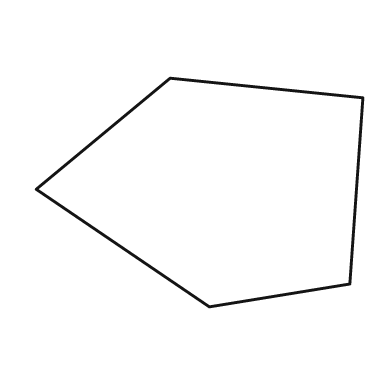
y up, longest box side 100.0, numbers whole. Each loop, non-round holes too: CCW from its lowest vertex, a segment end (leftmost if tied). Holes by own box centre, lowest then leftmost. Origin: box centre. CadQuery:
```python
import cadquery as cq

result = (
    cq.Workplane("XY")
    .moveTo(3.0, -35.0)
    .lineTo(46.0, -28.0)
    .lineTo(50.0, 29.0)
    .lineTo(-9.0, 35.0)
    .lineTo(-50.0, 1.0)
    .close()
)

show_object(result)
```